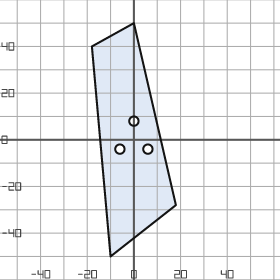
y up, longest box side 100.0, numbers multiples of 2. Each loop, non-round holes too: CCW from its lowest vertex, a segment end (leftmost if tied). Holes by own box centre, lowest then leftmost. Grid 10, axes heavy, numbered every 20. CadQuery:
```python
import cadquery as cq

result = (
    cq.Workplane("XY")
    .moveTo(-10.0, -50.0)
    .lineTo(18.0, -28.0)
    .lineTo(0.0, 50.0)
    .lineTo(-18.0, 40.0)
    .close()
    .moveTo(-6.0, -4.0)
    .circle(2.0)
    .moveTo(6.0, -4.0)
    .circle(2.0)
    .moveTo(0.0, 8.0)
    .circle(2.0)
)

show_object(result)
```